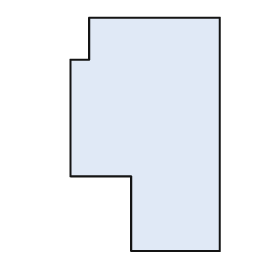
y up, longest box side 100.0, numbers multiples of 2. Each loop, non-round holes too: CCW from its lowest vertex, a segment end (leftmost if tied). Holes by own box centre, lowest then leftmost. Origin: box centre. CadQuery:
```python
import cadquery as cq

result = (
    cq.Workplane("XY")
    .moveTo(-6.0, -50.0)
    .lineTo(32.0, -50.0)
    .lineTo(32.0, 50.0)
    .lineTo(-24.0, 50.0)
    .lineTo(-24.0, 32.0)
    .lineTo(-32.0, 32.0)
    .lineTo(-32.0, -18.0)
    .lineTo(-6.0, -18.0)
    .close()
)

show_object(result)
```